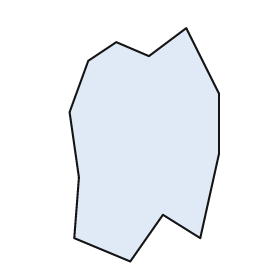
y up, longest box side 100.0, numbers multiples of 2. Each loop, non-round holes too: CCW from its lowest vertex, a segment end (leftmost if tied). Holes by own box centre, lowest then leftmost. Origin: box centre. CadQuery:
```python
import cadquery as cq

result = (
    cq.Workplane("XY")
    .moveTo(-6.0, -50.0)
    .lineTo(8.0, -30.0)
    .lineTo(24.0, -40.0)
    .lineTo(32.0, -4.0)
    .lineTo(32.0, 22.0)
    .lineTo(18.0, 50.0)
    .lineTo(2.0, 38.0)
    .lineTo(-12.0, 44.0)
    .lineTo(-24.0, 36.0)
    .lineTo(-32.0, 14.0)
    .lineTo(-28.0, -14.0)
    .lineTo(-30.0, -40.0)
    .close()
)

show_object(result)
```